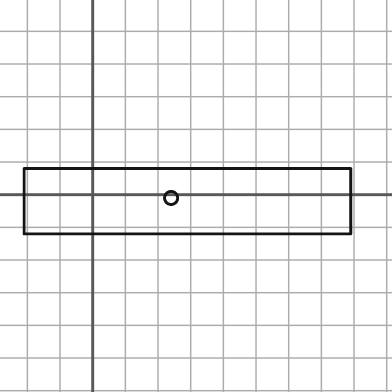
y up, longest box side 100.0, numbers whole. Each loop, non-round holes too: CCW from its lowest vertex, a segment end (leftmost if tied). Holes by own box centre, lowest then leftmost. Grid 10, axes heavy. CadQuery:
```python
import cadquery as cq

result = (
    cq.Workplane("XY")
    .moveTo(-21.0, -12.0)
    .lineTo(79.0, -12.0)
    .lineTo(79.0, 8.0)
    .lineTo(-21.0, 8.0)
    .close()
    .moveTo(24.0, -1.0)
    .circle(2.0)
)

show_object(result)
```